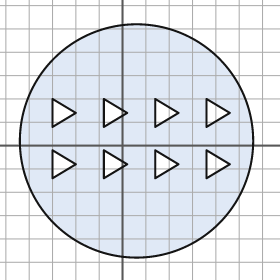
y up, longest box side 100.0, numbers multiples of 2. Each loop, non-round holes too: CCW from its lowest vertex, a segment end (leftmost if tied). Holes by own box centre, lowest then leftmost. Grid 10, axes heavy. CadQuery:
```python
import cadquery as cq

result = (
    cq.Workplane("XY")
    .moveTo(6.0, 2.0)
    .circle(50.0)
    .moveTo(-30.0, -14.0)
    .lineTo(-20.0, -8.0)
    .lineTo(-30.0, -2.0)
    .close()
    .moveTo(-8.0, -14.0)
    .lineTo(2.0, -8.0)
    .lineTo(-8.0, -2.0)
    .close()
    .moveTo(14.0, -14.0)
    .lineTo(24.0, -8.0)
    .lineTo(14.0, -2.0)
    .close()
    .moveTo(36.0, -14.0)
    .lineTo(46.0, -8.0)
    .lineTo(36.0, -2.0)
    .close()
    .moveTo(-30.0, 8.0)
    .lineTo(-20.0, 14.0)
    .lineTo(-30.0, 20.0)
    .close()
    .moveTo(-8.0, 8.0)
    .lineTo(2.0, 14.0)
    .lineTo(-8.0, 20.0)
    .close()
    .moveTo(14.0, 8.0)
    .lineTo(24.0, 14.0)
    .lineTo(14.0, 20.0)
    .close()
    .moveTo(36.0, 8.0)
    .lineTo(46.0, 14.0)
    .lineTo(36.0, 20.0)
    .close()
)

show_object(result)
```